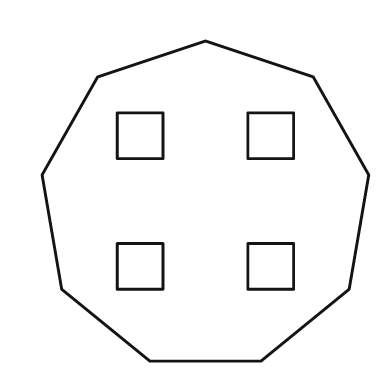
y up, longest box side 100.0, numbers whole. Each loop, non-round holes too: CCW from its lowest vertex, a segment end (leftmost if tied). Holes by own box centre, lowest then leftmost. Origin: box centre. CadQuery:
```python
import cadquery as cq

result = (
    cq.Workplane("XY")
    .moveTo(-17.0, -49.0)
    .lineTo(17.0, -49.0)
    .lineTo(44.0, -27.0)
    .lineTo(50.0, 8.0)
    .lineTo(33.0, 38.0)
    .lineTo(0.0, 49.0)
    .lineTo(-33.0, 38.0)
    .lineTo(-50.0, 8.0)
    .lineTo(-44.0, -27.0)
    .close()
    .moveTo(-27.0, -27.0)
    .lineTo(-13.0, -27.0)
    .lineTo(-13.0, -13.0)
    .lineTo(-27.0, -13.0)
    .close()
    .moveTo(13.0, -27.0)
    .lineTo(27.0, -27.0)
    .lineTo(27.0, -13.0)
    .lineTo(13.0, -13.0)
    .close()
    .moveTo(-27.0, 13.0)
    .lineTo(-13.0, 13.0)
    .lineTo(-13.0, 27.0)
    .lineTo(-27.0, 27.0)
    .close()
    .moveTo(13.0, 13.0)
    .lineTo(27.0, 13.0)
    .lineTo(27.0, 27.0)
    .lineTo(13.0, 27.0)
    .close()
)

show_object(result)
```